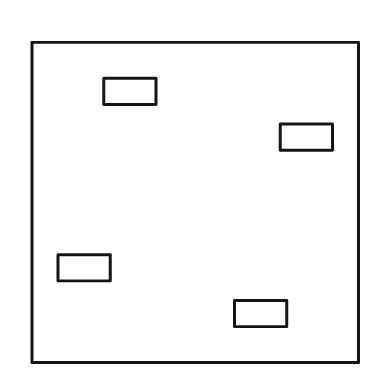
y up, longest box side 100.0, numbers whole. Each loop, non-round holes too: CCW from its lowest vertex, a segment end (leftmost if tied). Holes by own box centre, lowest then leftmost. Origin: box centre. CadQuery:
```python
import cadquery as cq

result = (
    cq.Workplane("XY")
    .moveTo(-50.0, -49.0)
    .lineTo(50.0, -49.0)
    .lineTo(50.0, 49.0)
    .lineTo(-50.0, 49.0)
    .close()
    .moveTo(12.0, -38.0)
    .lineTo(28.0, -38.0)
    .lineTo(28.0, -30.0)
    .lineTo(12.0, -30.0)
    .close()
    .moveTo(-42.0, -24.0)
    .lineTo(-26.0, -24.0)
    .lineTo(-26.0, -16.0)
    .lineTo(-42.0, -16.0)
    .close()
    .moveTo(26.0, 16.0)
    .lineTo(42.0, 16.0)
    .lineTo(42.0, 24.0)
    .lineTo(26.0, 24.0)
    .close()
    .moveTo(-28.0, 30.0)
    .lineTo(-12.0, 30.0)
    .lineTo(-12.0, 38.0)
    .lineTo(-28.0, 38.0)
    .close()
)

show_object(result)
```